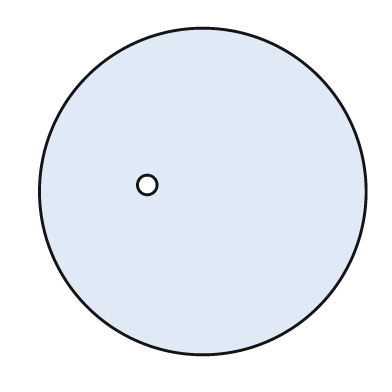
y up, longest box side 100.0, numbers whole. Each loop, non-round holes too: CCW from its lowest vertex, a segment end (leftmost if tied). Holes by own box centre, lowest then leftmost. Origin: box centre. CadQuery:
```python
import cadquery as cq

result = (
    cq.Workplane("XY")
    .moveTo(0.0, 0.0)
    .circle(50.0)
    .moveTo(-17.0, 2.0)
    .circle(3.0)
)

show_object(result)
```